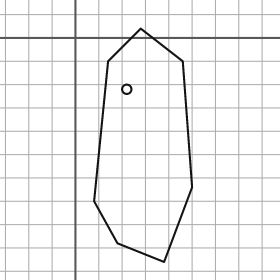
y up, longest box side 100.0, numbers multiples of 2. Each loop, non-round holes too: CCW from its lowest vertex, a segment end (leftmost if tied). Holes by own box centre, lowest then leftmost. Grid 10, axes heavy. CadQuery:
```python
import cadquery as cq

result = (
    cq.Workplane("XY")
    .moveTo(38.0, -96.0)
    .lineTo(50.0, -64.0)
    .lineTo(46.0, -10.0)
    .lineTo(28.0, 4.0)
    .lineTo(14.0, -10.0)
    .lineTo(8.0, -70.0)
    .lineTo(18.0, -88.0)
    .close()
    .moveTo(22.0, -22.0)
    .circle(2.0)
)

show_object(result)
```